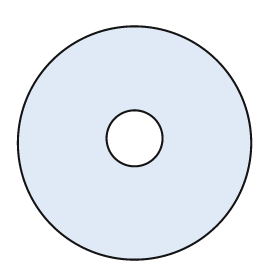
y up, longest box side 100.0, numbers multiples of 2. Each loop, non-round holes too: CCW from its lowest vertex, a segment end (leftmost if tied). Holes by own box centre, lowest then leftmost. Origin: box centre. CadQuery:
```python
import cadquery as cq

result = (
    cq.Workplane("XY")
    .moveTo(0.0, 0.0)
    .circle(50.0)
    .moveTo(0.0, 2.0)
    .circle(12.0)
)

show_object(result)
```